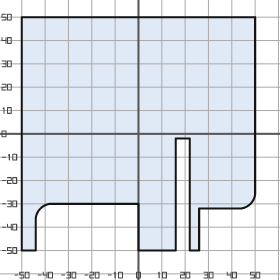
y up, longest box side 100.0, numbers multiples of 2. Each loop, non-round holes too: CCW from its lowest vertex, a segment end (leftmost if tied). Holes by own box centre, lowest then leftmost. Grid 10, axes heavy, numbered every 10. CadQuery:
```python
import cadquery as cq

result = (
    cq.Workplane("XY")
    .moveTo(-50.0, -50.0)
    .lineTo(-44.0, -50.0)
    .lineTo(-44.0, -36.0)
    .threePointArc((-42.0, -32.0), (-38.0, -30.0))
    .lineTo(0.0, -30.0)
    .lineTo(0.0, -50.0)
    .lineTo(16.0, -50.0)
    .lineTo(16.0, -2.0)
    .lineTo(22.0, -2.0)
    .lineTo(22.0, -50.0)
    .lineTo(26.0, -50.0)
    .lineTo(26.0, -32.0)
    .lineTo(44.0, -32.0)
    .threePointArc((48.0, -30.0), (50.0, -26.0))
    .lineTo(50.0, 50.0)
    .lineTo(-50.0, 50.0)
    .close()
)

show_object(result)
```